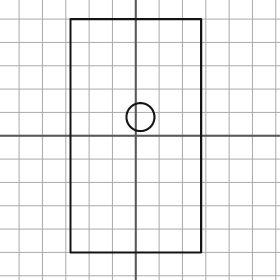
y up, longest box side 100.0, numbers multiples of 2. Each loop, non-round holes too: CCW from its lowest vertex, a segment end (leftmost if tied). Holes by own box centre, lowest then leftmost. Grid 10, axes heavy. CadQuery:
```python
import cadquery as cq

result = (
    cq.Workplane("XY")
    .moveTo(-28.0, -50.0)
    .lineTo(28.0, -50.0)
    .lineTo(28.0, 50.0)
    .lineTo(-28.0, 50.0)
    .close()
    .moveTo(2.0, 8.0)
    .circle(6.0)
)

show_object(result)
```